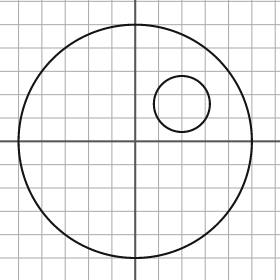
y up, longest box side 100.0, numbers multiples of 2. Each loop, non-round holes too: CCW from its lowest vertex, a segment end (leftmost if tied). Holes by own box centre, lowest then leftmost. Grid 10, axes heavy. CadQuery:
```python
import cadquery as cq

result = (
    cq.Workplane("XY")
    .moveTo(0.0, 0.0)
    .circle(50.0)
    .moveTo(20.0, 16.0)
    .circle(12.0)
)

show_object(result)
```